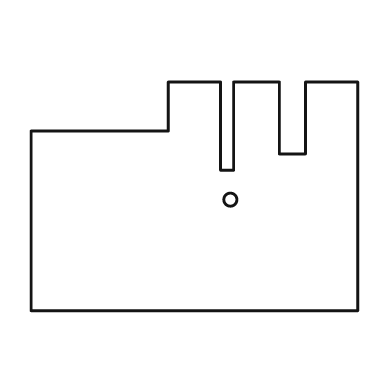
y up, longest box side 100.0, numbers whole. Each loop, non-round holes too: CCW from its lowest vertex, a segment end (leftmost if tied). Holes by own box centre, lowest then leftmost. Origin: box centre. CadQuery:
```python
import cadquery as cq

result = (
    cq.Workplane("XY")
    .moveTo(-50.0, -35.0)
    .lineTo(50.0, -35.0)
    .lineTo(50.0, 35.0)
    .lineTo(34.0, 35.0)
    .lineTo(34.0, 13.0)
    .lineTo(26.0, 13.0)
    .lineTo(26.0, 35.0)
    .lineTo(12.0, 35.0)
    .lineTo(12.0, 8.0)
    .lineTo(8.0, 8.0)
    .lineTo(8.0, 35.0)
    .lineTo(-8.0, 35.0)
    .lineTo(-8.0, 20.0)
    .lineTo(-50.0, 20.0)
    .close()
    .moveTo(11.0, -1.0)
    .circle(2.0)
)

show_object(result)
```